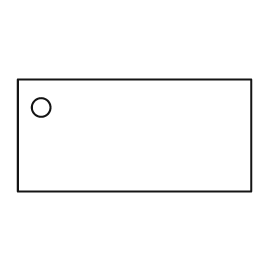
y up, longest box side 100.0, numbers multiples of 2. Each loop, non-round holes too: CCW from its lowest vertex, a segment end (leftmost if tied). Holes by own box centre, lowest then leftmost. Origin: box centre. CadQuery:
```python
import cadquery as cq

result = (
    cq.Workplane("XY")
    .moveTo(-50.0, -24.0)
    .lineTo(50.0, -24.0)
    .lineTo(50.0, 24.0)
    .lineTo(-50.0, 24.0)
    .close()
    .moveTo(-40.0, 12.0)
    .circle(4.0)
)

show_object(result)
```